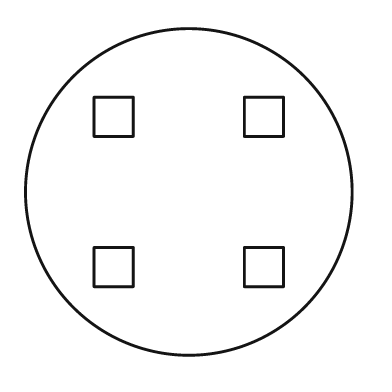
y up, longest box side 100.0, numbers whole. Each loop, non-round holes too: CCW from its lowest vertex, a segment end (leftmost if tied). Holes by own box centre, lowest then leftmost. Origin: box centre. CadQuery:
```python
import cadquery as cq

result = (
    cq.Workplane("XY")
    .moveTo(0.0, 0.0)
    .circle(50.0)
    .moveTo(-29.0, -29.0)
    .lineTo(-17.0, -29.0)
    .lineTo(-17.0, -17.0)
    .lineTo(-29.0, -17.0)
    .close()
    .moveTo(17.0, -29.0)
    .lineTo(29.0, -29.0)
    .lineTo(29.0, -17.0)
    .lineTo(17.0, -17.0)
    .close()
    .moveTo(-29.0, 17.0)
    .lineTo(-17.0, 17.0)
    .lineTo(-17.0, 29.0)
    .lineTo(-29.0, 29.0)
    .close()
    .moveTo(17.0, 17.0)
    .lineTo(29.0, 17.0)
    .lineTo(29.0, 29.0)
    .lineTo(17.0, 29.0)
    .close()
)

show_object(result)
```